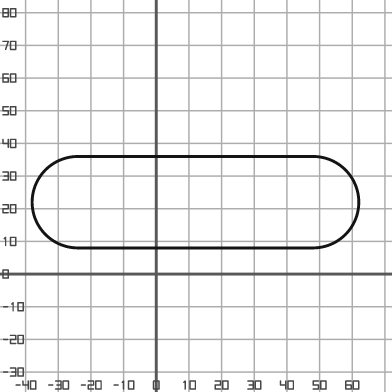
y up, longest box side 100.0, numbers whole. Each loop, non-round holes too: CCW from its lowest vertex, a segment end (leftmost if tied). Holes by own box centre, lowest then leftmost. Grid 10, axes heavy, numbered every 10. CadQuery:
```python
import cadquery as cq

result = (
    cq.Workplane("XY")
    .moveTo(-24.0, 8.0)
    .lineTo(48.0, 8.0)
    .threePointArc((62.0, 22.0), (48.0, 36.0))
    .lineTo(-24.0, 36.0)
    .threePointArc((-38.0, 22.0), (-24.0, 8.0))
    .close()
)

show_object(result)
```